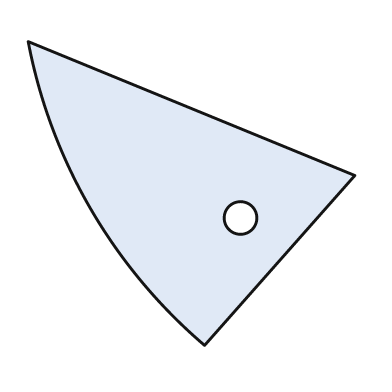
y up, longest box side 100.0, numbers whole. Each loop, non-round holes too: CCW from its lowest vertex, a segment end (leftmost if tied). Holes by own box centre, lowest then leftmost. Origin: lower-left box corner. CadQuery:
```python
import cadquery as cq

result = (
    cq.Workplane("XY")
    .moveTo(54.0, 0.0)
    .lineTo(100.0, 52.0)
    .lineTo(0.0, 93.0)
    .threePointArc((19.0, 42.0), (54.0, 0.0))
    .close()
    .moveTo(65.0, 39.0)
    .circle(5.0)
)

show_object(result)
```